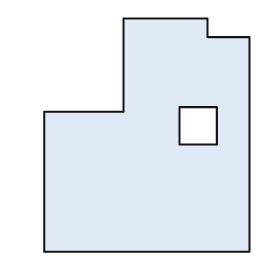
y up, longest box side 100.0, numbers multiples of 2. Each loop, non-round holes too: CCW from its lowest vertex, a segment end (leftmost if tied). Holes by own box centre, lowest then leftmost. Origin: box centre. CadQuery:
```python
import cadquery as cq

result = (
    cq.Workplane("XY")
    .moveTo(-44.0, -50.0)
    .lineTo(44.0, -50.0)
    .lineTo(44.0, 42.0)
    .lineTo(26.0, 42.0)
    .lineTo(26.0, 50.0)
    .lineTo(-10.0, 50.0)
    .lineTo(-10.0, 10.0)
    .lineTo(-44.0, 10.0)
    .close()
    .moveTo(14.0, -4.0)
    .lineTo(30.0, -4.0)
    .lineTo(30.0, 12.0)
    .lineTo(14.0, 12.0)
    .close()
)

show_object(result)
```